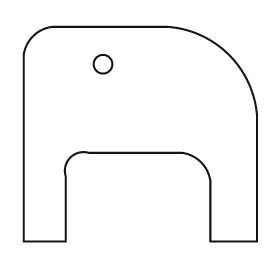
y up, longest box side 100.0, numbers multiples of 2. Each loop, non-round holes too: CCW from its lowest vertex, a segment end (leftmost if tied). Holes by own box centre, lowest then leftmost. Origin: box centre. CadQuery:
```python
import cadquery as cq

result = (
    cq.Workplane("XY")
    .moveTo(-50.0, -46.0)
    .lineTo(-32.0, -46.0)
    .lineTo(-32.0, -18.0)
    .threePointArc((-30.0, -10.0), (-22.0, -8.0))
    .lineTo(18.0, -8.0)
    .threePointArc((26.0, -12.0), (30.0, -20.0))
    .lineTo(30.0, -46.0)
    .lineTo(50.0, -46.0)
    .lineTo(50.0, 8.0)
    .threePointArc((38.0, 34.0), (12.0, 46.0))
    .lineTo(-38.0, 46.0)
    .threePointArc((-46.0, 42.0), (-50.0, 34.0))
    .close()
    .moveTo(-16.0, 30.0)
    .circle(4.0)
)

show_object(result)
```